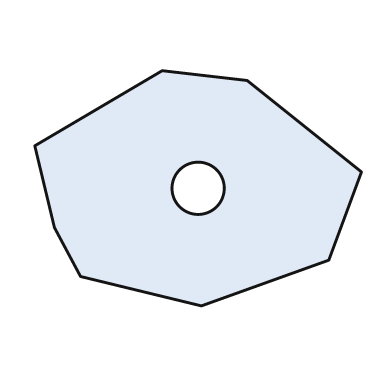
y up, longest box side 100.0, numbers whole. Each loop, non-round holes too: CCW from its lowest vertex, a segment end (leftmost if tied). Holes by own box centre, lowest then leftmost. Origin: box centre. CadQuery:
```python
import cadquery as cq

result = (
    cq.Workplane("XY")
    .moveTo(1.0, -36.0)
    .lineTo(40.0, -22.0)
    .lineTo(50.0, 5.0)
    .lineTo(15.0, 33.0)
    .lineTo(-11.0, 36.0)
    .lineTo(-50.0, 13.0)
    .lineTo(-44.0, -12.0)
    .lineTo(-36.0, -27.0)
    .close()
    .moveTo(0.0, 0.0)
    .circle(8.0)
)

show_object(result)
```